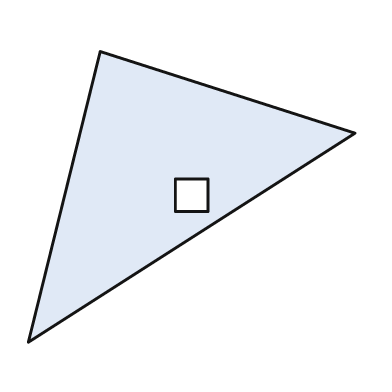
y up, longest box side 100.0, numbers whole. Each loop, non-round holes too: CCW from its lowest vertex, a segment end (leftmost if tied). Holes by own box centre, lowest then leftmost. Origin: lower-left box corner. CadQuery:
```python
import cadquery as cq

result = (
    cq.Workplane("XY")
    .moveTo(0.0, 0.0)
    .lineTo(100.0, 64.0)
    .lineTo(22.0, 89.0)
    .close()
    .moveTo(45.0, 40.0)
    .lineTo(55.0, 40.0)
    .lineTo(55.0, 50.0)
    .lineTo(45.0, 50.0)
    .close()
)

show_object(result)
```